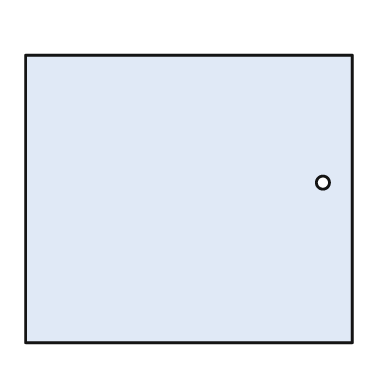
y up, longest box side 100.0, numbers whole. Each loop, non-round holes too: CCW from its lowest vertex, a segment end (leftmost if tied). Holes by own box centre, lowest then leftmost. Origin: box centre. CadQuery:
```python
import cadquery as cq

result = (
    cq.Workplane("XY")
    .moveTo(-50.0, -44.0)
    .lineTo(50.0, -44.0)
    .lineTo(50.0, 44.0)
    .lineTo(-50.0, 44.0)
    .close()
    .moveTo(41.0, 5.0)
    .circle(2.0)
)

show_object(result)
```